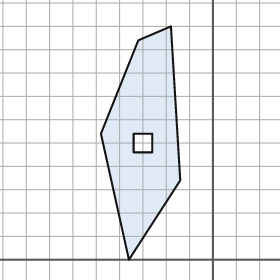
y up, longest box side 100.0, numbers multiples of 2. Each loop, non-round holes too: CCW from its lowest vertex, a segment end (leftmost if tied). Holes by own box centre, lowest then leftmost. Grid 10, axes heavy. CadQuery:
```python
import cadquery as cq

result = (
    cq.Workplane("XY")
    .moveTo(-36.0, 0.0)
    .lineTo(-14.0, 34.0)
    .lineTo(-18.0, 100.0)
    .lineTo(-32.0, 94.0)
    .lineTo(-48.0, 54.0)
    .close()
    .moveTo(-34.0, 46.0)
    .lineTo(-26.0, 46.0)
    .lineTo(-26.0, 54.0)
    .lineTo(-34.0, 54.0)
    .close()
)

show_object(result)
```